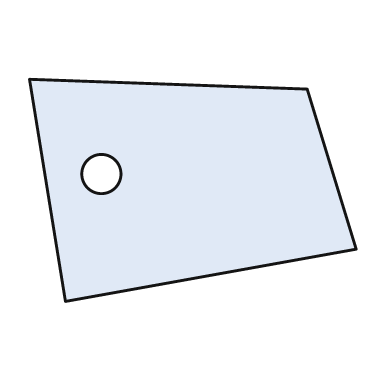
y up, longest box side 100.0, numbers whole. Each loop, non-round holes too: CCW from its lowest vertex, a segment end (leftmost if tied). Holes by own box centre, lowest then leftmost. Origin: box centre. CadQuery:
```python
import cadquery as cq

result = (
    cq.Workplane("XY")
    .moveTo(-39.0, -34.0)
    .lineTo(50.0, -18.0)
    .lineTo(35.0, 31.0)
    .lineTo(-50.0, 34.0)
    .close()
    .moveTo(-28.0, 5.0)
    .circle(6.0)
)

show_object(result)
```